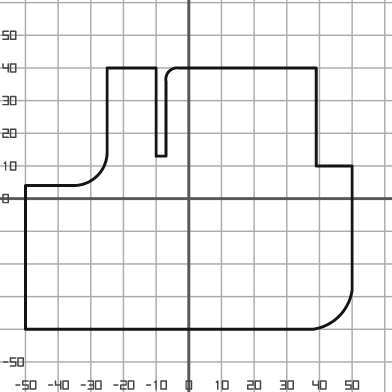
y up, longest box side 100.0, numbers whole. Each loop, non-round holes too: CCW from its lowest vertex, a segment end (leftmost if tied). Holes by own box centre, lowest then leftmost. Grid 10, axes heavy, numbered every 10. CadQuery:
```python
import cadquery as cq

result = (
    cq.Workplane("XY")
    .moveTo(-50.0, -40.0)
    .lineTo(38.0, -40.0)
    .threePointArc((46.0, -36.0), (50.0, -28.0))
    .lineTo(50.0, 10.0)
    .lineTo(39.0, 10.0)
    .lineTo(39.0, 40.0)
    .lineTo(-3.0, 40.0)
    .threePointArc((-6.0, 39.0), (-7.0, 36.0))
    .lineTo(-7.0, 13.0)
    .lineTo(-10.0, 13.0)
    .lineTo(-10.0, 40.0)
    .lineTo(-25.0, 40.0)
    .lineTo(-25.0, 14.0)
    .threePointArc((-28.0, 7.0), (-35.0, 4.0))
    .lineTo(-50.0, 4.0)
    .close()
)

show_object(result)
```